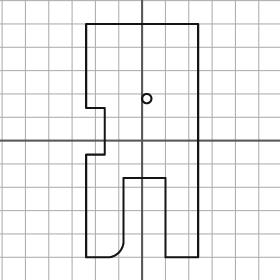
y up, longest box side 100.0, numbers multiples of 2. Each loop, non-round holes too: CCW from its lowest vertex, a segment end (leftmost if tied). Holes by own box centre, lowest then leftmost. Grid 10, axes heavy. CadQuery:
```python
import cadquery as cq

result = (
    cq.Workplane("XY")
    .moveTo(-24.0, -50.0)
    .lineTo(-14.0, -50.0)
    .threePointArc((-10.0, -48.0), (-8.0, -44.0))
    .lineTo(-8.0, -16.0)
    .lineTo(10.0, -16.0)
    .lineTo(10.0, -50.0)
    .lineTo(24.0, -50.0)
    .lineTo(24.0, 50.0)
    .lineTo(-24.0, 50.0)
    .lineTo(-24.0, 14.0)
    .lineTo(-16.0, 14.0)
    .lineTo(-16.0, -6.0)
    .lineTo(-24.0, -6.0)
    .close()
    .moveTo(2.0, 18.0)
    .circle(2.0)
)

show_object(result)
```